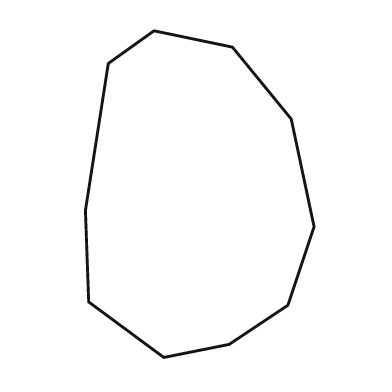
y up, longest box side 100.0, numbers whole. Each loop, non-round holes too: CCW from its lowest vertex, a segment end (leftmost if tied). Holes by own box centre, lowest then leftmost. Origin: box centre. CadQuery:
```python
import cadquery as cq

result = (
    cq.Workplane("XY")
    .moveTo(-11.0, -50.0)
    .lineTo(9.0, -46.0)
    .lineTo(27.0, -34.0)
    .lineTo(35.0, -10.0)
    .lineTo(28.0, 23.0)
    .lineTo(10.0, 45.0)
    .lineTo(-14.0, 50.0)
    .lineTo(-28.0, 40.0)
    .lineTo(-35.0, -5.0)
    .lineTo(-34.0, -33.0)
    .close()
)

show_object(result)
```